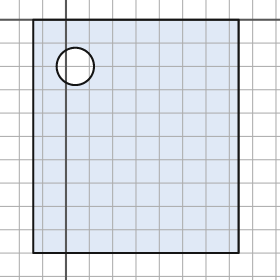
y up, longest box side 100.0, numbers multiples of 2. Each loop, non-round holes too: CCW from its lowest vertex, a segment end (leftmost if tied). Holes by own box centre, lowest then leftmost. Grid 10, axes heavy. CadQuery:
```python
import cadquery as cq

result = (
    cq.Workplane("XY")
    .moveTo(-14.0, -100.0)
    .lineTo(74.0, -100.0)
    .lineTo(74.0, 0.0)
    .lineTo(-14.0, 0.0)
    .close()
    .moveTo(4.0, -20.0)
    .circle(8.0)
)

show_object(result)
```